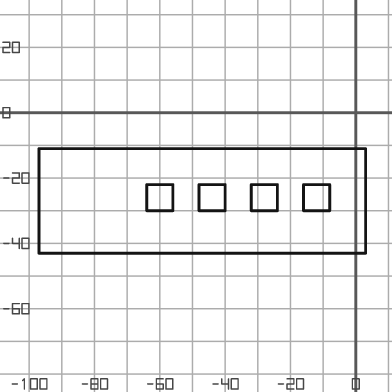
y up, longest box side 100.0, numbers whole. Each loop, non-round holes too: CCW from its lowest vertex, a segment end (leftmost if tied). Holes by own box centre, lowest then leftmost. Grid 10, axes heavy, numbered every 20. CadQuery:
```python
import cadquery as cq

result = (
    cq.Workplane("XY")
    .moveTo(-97.0, -43.0)
    .lineTo(3.0, -43.0)
    .lineTo(3.0, -11.0)
    .lineTo(-97.0, -11.0)
    .close()
    .moveTo(-64.0, -30.0)
    .lineTo(-56.0, -30.0)
    .lineTo(-56.0, -22.0)
    .lineTo(-64.0, -22.0)
    .close()
    .moveTo(-48.0, -30.0)
    .lineTo(-40.0, -30.0)
    .lineTo(-40.0, -22.0)
    .lineTo(-48.0, -22.0)
    .close()
    .moveTo(-32.0, -30.0)
    .lineTo(-24.0, -30.0)
    .lineTo(-24.0, -22.0)
    .lineTo(-32.0, -22.0)
    .close()
    .moveTo(-16.0, -30.0)
    .lineTo(-8.0, -30.0)
    .lineTo(-8.0, -22.0)
    .lineTo(-16.0, -22.0)
    .close()
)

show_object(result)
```